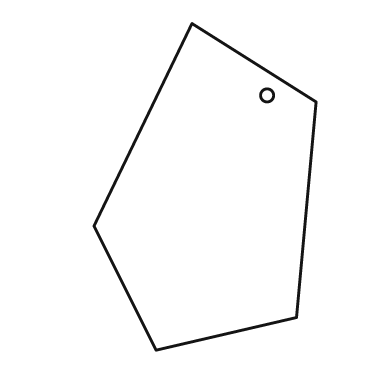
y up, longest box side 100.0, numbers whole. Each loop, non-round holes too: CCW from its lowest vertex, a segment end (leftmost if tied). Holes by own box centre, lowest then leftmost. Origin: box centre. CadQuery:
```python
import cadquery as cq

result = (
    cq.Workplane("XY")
    .moveTo(-15.0, -50.0)
    .lineTo(28.0, -40.0)
    .lineTo(34.0, 26.0)
    .lineTo(-4.0, 50.0)
    .lineTo(-34.0, -12.0)
    .close()
    .moveTo(19.0, 28.0)
    .circle(2.0)
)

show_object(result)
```